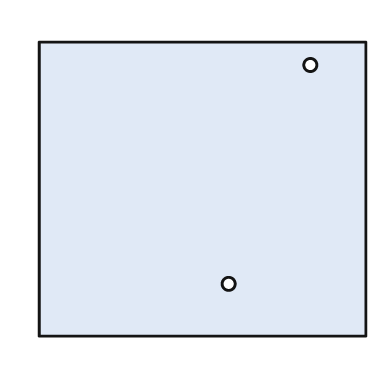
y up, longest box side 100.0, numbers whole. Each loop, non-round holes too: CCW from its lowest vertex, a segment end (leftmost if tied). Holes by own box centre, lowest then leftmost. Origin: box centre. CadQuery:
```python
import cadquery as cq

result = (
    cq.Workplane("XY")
    .moveTo(-50.0, -45.0)
    .lineTo(50.0, -45.0)
    .lineTo(50.0, 45.0)
    .lineTo(-50.0, 45.0)
    .close()
    .moveTo(8.0, -29.0)
    .circle(2.0)
    .moveTo(33.0, 38.0)
    .circle(2.0)
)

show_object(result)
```